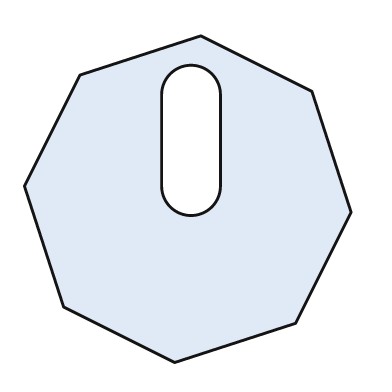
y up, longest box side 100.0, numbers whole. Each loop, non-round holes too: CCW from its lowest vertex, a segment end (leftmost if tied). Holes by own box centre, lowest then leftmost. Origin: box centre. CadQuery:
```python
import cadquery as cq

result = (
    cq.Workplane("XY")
    .moveTo(-4.0, -50.0)
    .lineTo(33.0, -38.0)
    .lineTo(50.0, -4.0)
    .lineTo(38.0, 33.0)
    .lineTo(4.0, 50.0)
    .lineTo(-33.0, 38.0)
    .lineTo(-50.0, 4.0)
    .lineTo(-38.0, -33.0)
    .close()
    .moveTo(-8.0, 4.0)
    .threePointArc((1.0, -5.0), (10.0, 4.0))
    .lineTo(10.0, 32.0)
    .threePointArc((1.0, 41.0), (-8.0, 32.0))
    .close()
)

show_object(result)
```